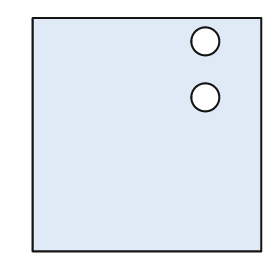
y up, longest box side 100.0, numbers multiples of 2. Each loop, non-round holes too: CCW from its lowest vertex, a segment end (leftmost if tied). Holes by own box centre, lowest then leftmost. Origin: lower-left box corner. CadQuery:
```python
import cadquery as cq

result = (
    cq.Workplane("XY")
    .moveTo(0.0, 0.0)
    .lineTo(98.0, 0.0)
    .lineTo(98.0, 100.0)
    .lineTo(0.0, 100.0)
    .close()
    .moveTo(74.0, 66.0)
    .circle(6.0)
    .moveTo(74.0, 90.0)
    .circle(6.0)
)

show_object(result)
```